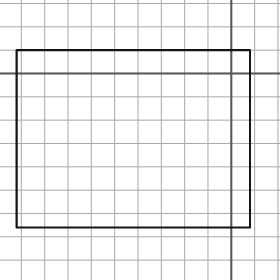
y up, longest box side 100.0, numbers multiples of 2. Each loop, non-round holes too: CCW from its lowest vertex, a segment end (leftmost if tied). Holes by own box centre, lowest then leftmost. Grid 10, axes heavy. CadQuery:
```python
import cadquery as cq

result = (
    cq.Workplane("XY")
    .moveTo(-92.0, -66.0)
    .lineTo(8.0, -66.0)
    .lineTo(8.0, 10.0)
    .lineTo(-92.0, 10.0)
    .close()
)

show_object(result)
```